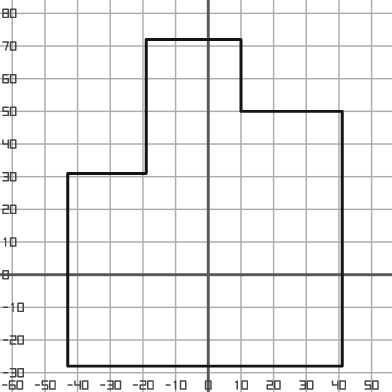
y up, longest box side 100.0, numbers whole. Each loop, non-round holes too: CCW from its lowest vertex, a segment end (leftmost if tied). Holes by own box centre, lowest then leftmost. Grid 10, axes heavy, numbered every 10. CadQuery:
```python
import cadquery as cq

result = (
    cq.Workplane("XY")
    .moveTo(-43.0, -28.0)
    .lineTo(41.0, -28.0)
    .lineTo(41.0, 50.0)
    .lineTo(10.0, 50.0)
    .lineTo(10.0, 72.0)
    .lineTo(-19.0, 72.0)
    .lineTo(-19.0, 31.0)
    .lineTo(-43.0, 31.0)
    .close()
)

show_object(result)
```